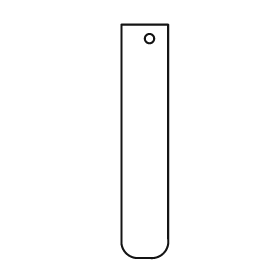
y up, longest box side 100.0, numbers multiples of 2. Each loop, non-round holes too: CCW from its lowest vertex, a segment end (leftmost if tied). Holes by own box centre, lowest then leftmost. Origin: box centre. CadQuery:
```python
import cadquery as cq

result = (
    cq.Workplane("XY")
    .moveTo(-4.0, -50.0)
    .lineTo(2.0, -50.0)
    .threePointArc((8.0, -48.0), (10.0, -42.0))
    .lineTo(10.0, 50.0)
    .lineTo(-10.0, 50.0)
    .lineTo(-10.0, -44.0)
    .threePointArc((-8.0, -48.0), (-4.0, -50.0))
    .close()
    .moveTo(2.0, 44.0)
    .circle(2.0)
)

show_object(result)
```